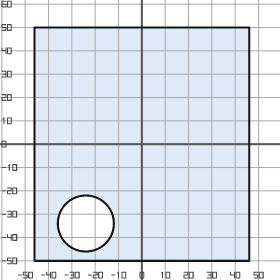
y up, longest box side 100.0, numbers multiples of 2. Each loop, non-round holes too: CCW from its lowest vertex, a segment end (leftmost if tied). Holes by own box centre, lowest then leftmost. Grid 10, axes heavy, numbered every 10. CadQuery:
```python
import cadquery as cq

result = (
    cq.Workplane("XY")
    .moveTo(-46.0, -50.0)
    .lineTo(46.0, -50.0)
    .lineTo(46.0, 50.0)
    .lineTo(-46.0, 50.0)
    .close()
    .moveTo(-24.0, -34.0)
    .circle(12.0)
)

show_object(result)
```